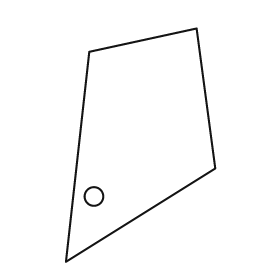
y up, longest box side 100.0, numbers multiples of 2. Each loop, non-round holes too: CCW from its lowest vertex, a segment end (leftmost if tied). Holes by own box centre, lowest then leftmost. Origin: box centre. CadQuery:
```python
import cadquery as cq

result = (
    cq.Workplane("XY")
    .moveTo(-32.0, -50.0)
    .lineTo(32.0, -10.0)
    .lineTo(24.0, 50.0)
    .lineTo(-22.0, 40.0)
    .close()
    .moveTo(-20.0, -22.0)
    .circle(4.0)
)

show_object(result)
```